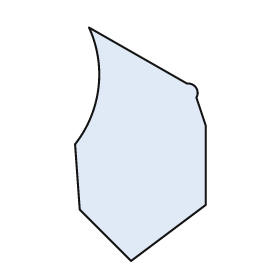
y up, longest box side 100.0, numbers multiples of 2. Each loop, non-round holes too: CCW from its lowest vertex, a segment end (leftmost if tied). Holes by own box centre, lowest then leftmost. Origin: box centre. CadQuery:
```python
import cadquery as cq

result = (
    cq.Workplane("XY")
    .moveTo(-4.0, -50.0)
    .lineTo(28.0, -26.0)
    .lineTo(28.0, 8.0)
    .lineTo(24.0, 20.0)
    .threePointArc((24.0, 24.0), (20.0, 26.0))
    .lineTo(-22.0, 50.0)
    .threePointArc((-18.0, 24.0), (-28.0, 0.0))
    .lineTo(-26.0, -28.0)
    .close()
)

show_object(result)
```